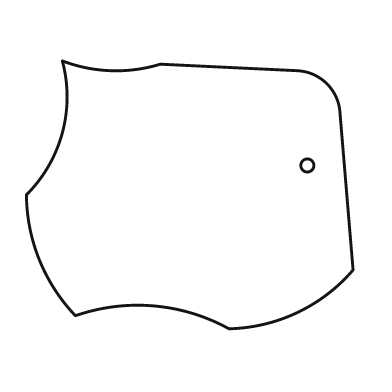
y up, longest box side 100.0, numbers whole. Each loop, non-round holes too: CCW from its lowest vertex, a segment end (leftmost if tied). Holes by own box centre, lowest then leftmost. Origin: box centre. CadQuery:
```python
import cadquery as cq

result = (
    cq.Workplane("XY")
    .moveTo(12.0, -41.0)
    .threePointArc((33.0, -36.0), (50.0, -23.0))
    .lineTo(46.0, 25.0)
    .threePointArc((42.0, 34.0), (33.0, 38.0))
    .lineTo(-9.0, 40.0)
    .threePointArc((-24.0, 38.0), (-39.0, 41.0))
    .threePointArc((-39.0, 19.0), (-50.0, 0.0))
    .threePointArc((-46.0, -20.0), (-35.0, -37.0))
    .threePointArc((-11.0, -34.0), (12.0, -41.0))
    .close()
    .moveTo(36.0, 9.0)
    .circle(2.0)
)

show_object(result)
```